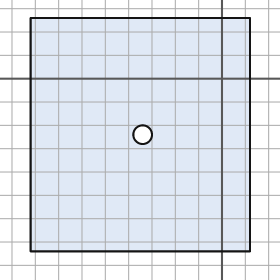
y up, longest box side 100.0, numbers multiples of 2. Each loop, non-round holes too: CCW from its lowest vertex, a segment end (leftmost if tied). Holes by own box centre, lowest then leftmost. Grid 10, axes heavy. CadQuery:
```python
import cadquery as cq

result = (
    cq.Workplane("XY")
    .moveTo(-82.0, -74.0)
    .lineTo(12.0, -74.0)
    .lineTo(12.0, 26.0)
    .lineTo(-82.0, 26.0)
    .close()
    .moveTo(-34.0, -24.0)
    .circle(4.0)
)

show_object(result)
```